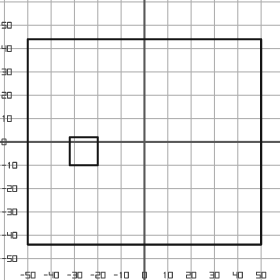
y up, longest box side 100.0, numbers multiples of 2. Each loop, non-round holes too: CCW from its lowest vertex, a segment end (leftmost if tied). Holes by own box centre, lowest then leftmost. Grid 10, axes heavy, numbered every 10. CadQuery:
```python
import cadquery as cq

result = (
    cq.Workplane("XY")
    .moveTo(-50.0, -44.0)
    .lineTo(50.0, -44.0)
    .lineTo(50.0, 44.0)
    .lineTo(-50.0, 44.0)
    .close()
    .moveTo(-32.0, -10.0)
    .lineTo(-20.0, -10.0)
    .lineTo(-20.0, 2.0)
    .lineTo(-32.0, 2.0)
    .close()
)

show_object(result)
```